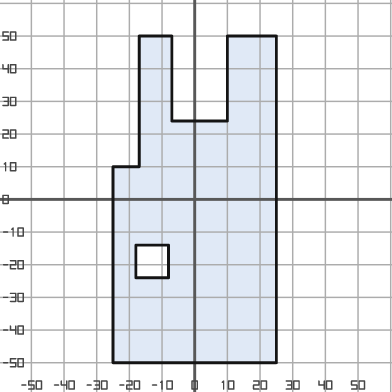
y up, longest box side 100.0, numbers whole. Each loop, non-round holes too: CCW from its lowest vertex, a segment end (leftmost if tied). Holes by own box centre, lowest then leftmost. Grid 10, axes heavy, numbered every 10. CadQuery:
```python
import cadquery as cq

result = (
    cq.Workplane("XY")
    .moveTo(-25.0, -50.0)
    .lineTo(25.0, -50.0)
    .lineTo(25.0, 50.0)
    .lineTo(10.0, 50.0)
    .lineTo(10.0, 24.0)
    .lineTo(-7.0, 24.0)
    .lineTo(-7.0, 50.0)
    .lineTo(-17.0, 50.0)
    .lineTo(-17.0, 10.0)
    .lineTo(-25.0, 10.0)
    .close()
    .moveTo(-18.0, -24.0)
    .lineTo(-8.0, -24.0)
    .lineTo(-8.0, -14.0)
    .lineTo(-18.0, -14.0)
    .close()
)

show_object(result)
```